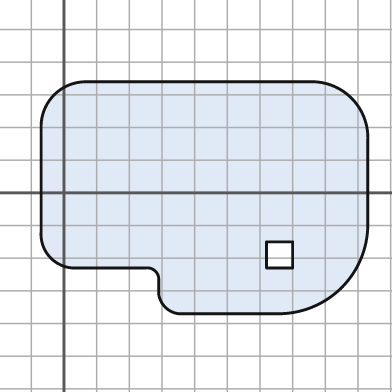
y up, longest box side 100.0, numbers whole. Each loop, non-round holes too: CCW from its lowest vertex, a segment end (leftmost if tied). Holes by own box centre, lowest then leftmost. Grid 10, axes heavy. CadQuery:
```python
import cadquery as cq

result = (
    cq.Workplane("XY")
    .moveTo(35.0, -37.0)
    .lineTo(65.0, -37.0)
    .threePointArc((85.0, -29.0), (93.0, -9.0))
    .lineTo(93.0, 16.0)
    .threePointArc((88.0, 29.0), (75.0, 34.0))
    .lineTo(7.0, 34.0)
    .threePointArc((-3.0, 30.0), (-7.0, 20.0))
    .lineTo(-7.0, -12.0)
    .threePointArc((-4.0, -20.0), (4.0, -23.0))
    .lineTo(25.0, -23.0)
    .threePointArc((28.0, -24.0), (29.0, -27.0))
    .lineTo(29.0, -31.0)
    .threePointArc((31.0, -35.0), (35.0, -37.0))
    .close()
    .moveTo(62.0, -23.0)
    .lineTo(70.0, -23.0)
    .lineTo(70.0, -15.0)
    .lineTo(62.0, -15.0)
    .close()
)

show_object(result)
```